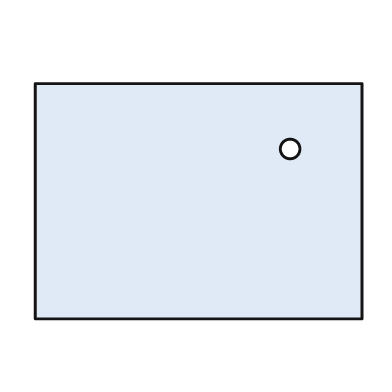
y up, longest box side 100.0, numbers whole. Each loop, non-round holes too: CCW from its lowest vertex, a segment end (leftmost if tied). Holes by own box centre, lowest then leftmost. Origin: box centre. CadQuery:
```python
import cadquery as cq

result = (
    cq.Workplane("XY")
    .moveTo(-50.0, -36.0)
    .lineTo(50.0, -36.0)
    .lineTo(50.0, 36.0)
    .lineTo(-50.0, 36.0)
    .close()
    .moveTo(28.0, 16.0)
    .circle(3.0)
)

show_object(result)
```